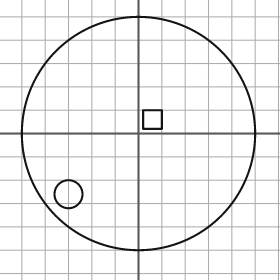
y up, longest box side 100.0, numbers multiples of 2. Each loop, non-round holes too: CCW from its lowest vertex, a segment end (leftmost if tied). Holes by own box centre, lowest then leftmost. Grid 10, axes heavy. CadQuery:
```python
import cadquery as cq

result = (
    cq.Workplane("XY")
    .moveTo(0.0, 0.0)
    .circle(50.0)
    .moveTo(-30.0, -26.0)
    .circle(6.0)
    .moveTo(2.0, 2.0)
    .lineTo(10.0, 2.0)
    .lineTo(10.0, 10.0)
    .lineTo(2.0, 10.0)
    .close()
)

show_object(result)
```